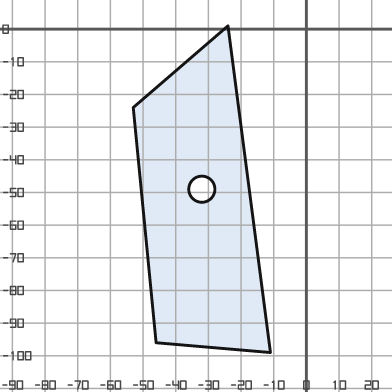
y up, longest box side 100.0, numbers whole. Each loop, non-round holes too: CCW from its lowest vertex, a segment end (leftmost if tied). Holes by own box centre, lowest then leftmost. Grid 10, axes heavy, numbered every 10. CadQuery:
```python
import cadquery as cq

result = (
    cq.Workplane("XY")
    .moveTo(-11.0, -99.0)
    .lineTo(-24.0, 1.0)
    .lineTo(-53.0, -24.0)
    .lineTo(-46.0, -96.0)
    .close()
    .moveTo(-32.0, -49.0)
    .circle(4.0)
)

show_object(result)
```